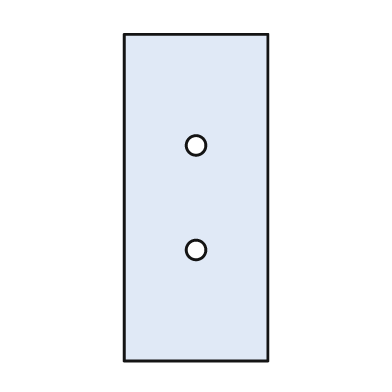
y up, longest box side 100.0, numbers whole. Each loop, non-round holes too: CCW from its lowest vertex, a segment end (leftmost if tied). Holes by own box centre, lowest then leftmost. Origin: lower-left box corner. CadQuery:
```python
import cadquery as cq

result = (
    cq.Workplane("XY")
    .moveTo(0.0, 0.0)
    .lineTo(44.0, 0.0)
    .lineTo(44.0, 100.0)
    .lineTo(0.0, 100.0)
    .close()
    .moveTo(22.0, 34.0)
    .circle(3.0)
    .moveTo(22.0, 66.0)
    .circle(3.0)
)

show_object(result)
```